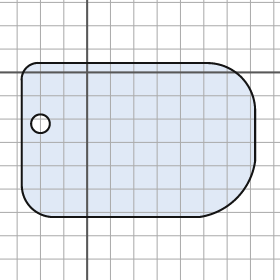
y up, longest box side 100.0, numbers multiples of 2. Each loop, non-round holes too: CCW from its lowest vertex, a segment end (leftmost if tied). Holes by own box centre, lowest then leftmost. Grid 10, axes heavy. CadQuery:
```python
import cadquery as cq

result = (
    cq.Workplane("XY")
    .moveTo(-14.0, -62.0)
    .lineTo(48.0, -62.0)
    .threePointArc((64.0, -54.0), (72.0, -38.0))
    .lineTo(72.0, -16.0)
    .threePointArc((66.0, -2.0), (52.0, 4.0))
    .lineTo(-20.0, 4.0)
    .threePointArc((-26.0, 2.0), (-28.0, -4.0))
    .lineTo(-28.0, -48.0)
    .threePointArc((-24.0, -58.0), (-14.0, -62.0))
    .close()
    .moveTo(-20.0, -22.0)
    .circle(4.0)
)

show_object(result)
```